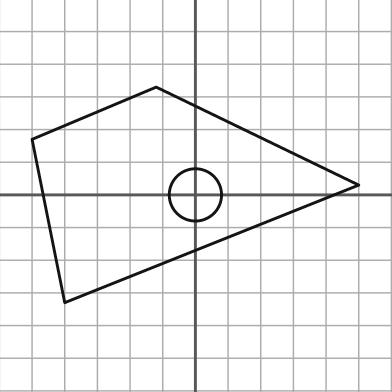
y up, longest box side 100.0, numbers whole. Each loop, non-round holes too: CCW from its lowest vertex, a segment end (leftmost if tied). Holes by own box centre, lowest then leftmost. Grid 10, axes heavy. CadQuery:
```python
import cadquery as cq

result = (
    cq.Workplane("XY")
    .moveTo(-40.0, -33.0)
    .lineTo(50.0, 3.0)
    .lineTo(-12.0, 33.0)
    .lineTo(-50.0, 17.0)
    .close()
    .moveTo(0.0, 0.0)
    .circle(8.0)
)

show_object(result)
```